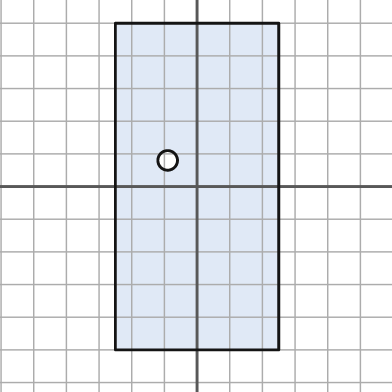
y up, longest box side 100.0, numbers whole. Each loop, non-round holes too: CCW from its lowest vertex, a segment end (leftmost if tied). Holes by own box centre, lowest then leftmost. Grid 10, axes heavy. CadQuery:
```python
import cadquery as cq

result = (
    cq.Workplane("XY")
    .moveTo(-25.0, -50.0)
    .lineTo(25.0, -50.0)
    .lineTo(25.0, 50.0)
    .lineTo(-25.0, 50.0)
    .close()
    .moveTo(-9.0, 8.0)
    .circle(3.0)
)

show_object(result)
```